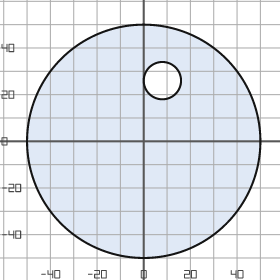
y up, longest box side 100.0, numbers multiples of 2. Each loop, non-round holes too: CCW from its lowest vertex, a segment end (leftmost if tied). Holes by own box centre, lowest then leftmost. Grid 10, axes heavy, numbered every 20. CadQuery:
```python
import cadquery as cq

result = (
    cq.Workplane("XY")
    .moveTo(0.0, 0.0)
    .circle(50.0)
    .moveTo(8.0, 26.0)
    .circle(8.0)
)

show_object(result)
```